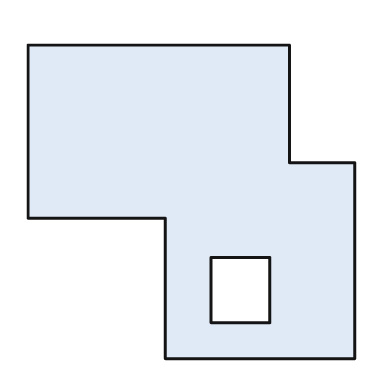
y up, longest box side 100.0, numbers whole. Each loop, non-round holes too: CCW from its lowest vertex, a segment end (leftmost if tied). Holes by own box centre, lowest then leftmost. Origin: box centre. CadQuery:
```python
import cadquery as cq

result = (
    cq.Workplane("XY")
    .moveTo(-8.0, -48.0)
    .lineTo(50.0, -48.0)
    .lineTo(50.0, 12.0)
    .lineTo(30.0, 12.0)
    .lineTo(30.0, 48.0)
    .lineTo(-50.0, 48.0)
    .lineTo(-50.0, -5.0)
    .lineTo(-8.0, -5.0)
    .close()
    .moveTo(6.0, -37.0)
    .lineTo(24.0, -37.0)
    .lineTo(24.0, -17.0)
    .lineTo(6.0, -17.0)
    .close()
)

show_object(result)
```